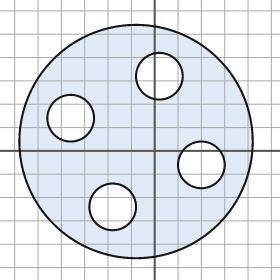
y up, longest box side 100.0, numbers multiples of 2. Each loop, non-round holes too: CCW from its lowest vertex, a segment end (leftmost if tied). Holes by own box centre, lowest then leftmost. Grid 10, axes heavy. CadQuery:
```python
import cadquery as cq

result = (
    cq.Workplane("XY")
    .moveTo(-8.0, 4.0)
    .circle(50.0)
    .moveTo(-18.0, -24.0)
    .circle(10.0)
    .moveTo(20.0, -6.0)
    .circle(10.0)
    .moveTo(-36.0, 14.0)
    .circle(10.0)
    .moveTo(2.0, 32.0)
    .circle(10.0)
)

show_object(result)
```